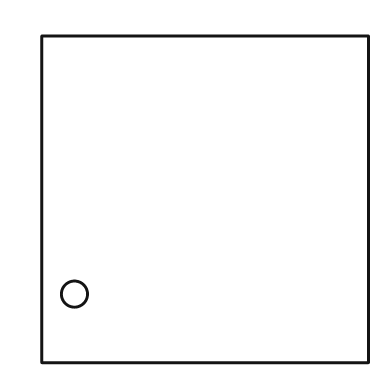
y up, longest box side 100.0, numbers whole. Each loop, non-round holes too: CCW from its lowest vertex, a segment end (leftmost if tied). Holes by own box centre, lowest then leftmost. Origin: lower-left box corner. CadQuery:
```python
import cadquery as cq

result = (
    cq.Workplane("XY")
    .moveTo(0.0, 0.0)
    .lineTo(100.0, 0.0)
    .lineTo(100.0, 100.0)
    .lineTo(0.0, 100.0)
    .close()
    .moveTo(10.0, 21.0)
    .circle(4.0)
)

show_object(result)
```